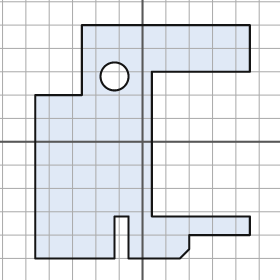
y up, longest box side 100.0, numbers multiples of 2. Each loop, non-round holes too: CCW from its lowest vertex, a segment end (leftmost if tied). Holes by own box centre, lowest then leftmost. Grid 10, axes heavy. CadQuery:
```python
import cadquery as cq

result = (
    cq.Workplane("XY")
    .moveTo(-46.0, -50.0)
    .lineTo(-12.0, -50.0)
    .lineTo(-12.0, -32.0)
    .lineTo(-6.0, -32.0)
    .lineTo(-6.0, -50.0)
    .lineTo(16.0, -50.0)
    .lineTo(20.0, -46.0)
    .lineTo(20.0, -40.0)
    .lineTo(46.0, -40.0)
    .lineTo(46.0, -32.0)
    .lineTo(4.0, -32.0)
    .lineTo(4.0, 30.0)
    .lineTo(46.0, 30.0)
    .lineTo(46.0, 50.0)
    .lineTo(-26.0, 50.0)
    .lineTo(-26.0, 20.0)
    .lineTo(-46.0, 20.0)
    .close()
    .moveTo(-12.0, 28.0)
    .circle(6.0)
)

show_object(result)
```